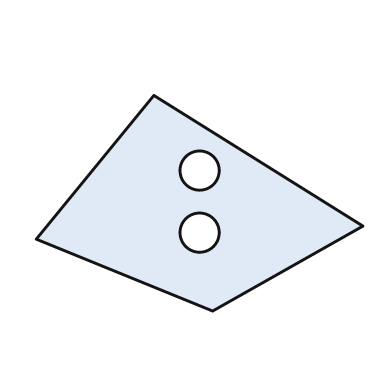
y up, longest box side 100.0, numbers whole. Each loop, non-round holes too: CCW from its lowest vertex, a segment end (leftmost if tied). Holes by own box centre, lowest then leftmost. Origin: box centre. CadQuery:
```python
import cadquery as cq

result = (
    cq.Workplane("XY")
    .moveTo(4.0, -33.0)
    .lineTo(50.0, -7.0)
    .lineTo(-14.0, 33.0)
    .lineTo(-50.0, -11.0)
    .close()
    .moveTo(0.0, -9.0)
    .circle(6.0)
    .moveTo(0.0, 10.0)
    .circle(6.0)
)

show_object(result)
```